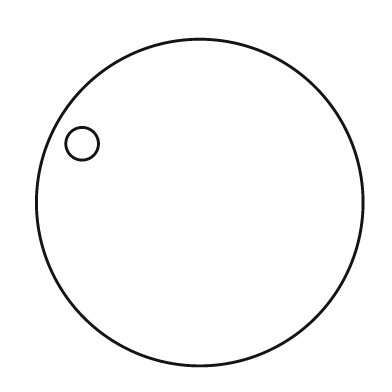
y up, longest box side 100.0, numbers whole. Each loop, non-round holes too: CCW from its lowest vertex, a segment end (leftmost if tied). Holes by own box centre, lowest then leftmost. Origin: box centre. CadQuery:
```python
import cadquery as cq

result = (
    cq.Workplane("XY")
    .moveTo(0.0, 0.0)
    .circle(50.0)
    .moveTo(-36.0, 18.0)
    .circle(5.0)
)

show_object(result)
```